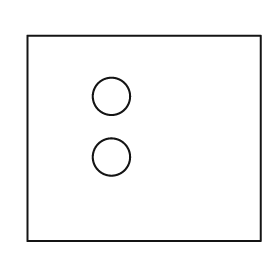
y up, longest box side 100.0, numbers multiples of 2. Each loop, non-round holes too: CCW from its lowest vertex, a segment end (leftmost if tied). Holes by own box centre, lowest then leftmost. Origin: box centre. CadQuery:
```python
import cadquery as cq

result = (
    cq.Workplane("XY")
    .moveTo(-50.0, -44.0)
    .lineTo(50.0, -44.0)
    .lineTo(50.0, 44.0)
    .lineTo(-50.0, 44.0)
    .close()
    .moveTo(-14.0, -8.0)
    .circle(8.0)
    .moveTo(-14.0, 18.0)
    .circle(8.0)
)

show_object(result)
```